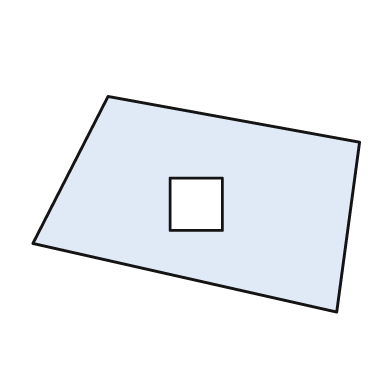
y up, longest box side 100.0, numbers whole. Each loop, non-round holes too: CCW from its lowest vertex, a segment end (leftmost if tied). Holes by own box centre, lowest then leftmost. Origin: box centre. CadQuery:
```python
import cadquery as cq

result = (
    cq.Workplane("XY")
    .moveTo(43.0, -33.0)
    .lineTo(50.0, 19.0)
    .lineTo(-27.0, 33.0)
    .lineTo(-50.0, -12.0)
    .close()
    .moveTo(-8.0, -8.0)
    .lineTo(8.0, -8.0)
    .lineTo(8.0, 8.0)
    .lineTo(-8.0, 8.0)
    .close()
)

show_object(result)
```